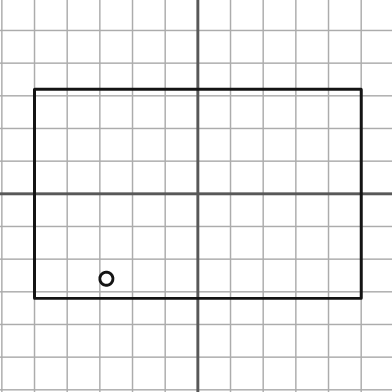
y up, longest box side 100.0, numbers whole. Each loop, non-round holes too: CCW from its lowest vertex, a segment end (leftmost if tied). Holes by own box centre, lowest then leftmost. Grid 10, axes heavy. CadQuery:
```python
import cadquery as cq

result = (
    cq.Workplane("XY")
    .moveTo(-50.0, -32.0)
    .lineTo(50.0, -32.0)
    .lineTo(50.0, 32.0)
    .lineTo(-50.0, 32.0)
    .close()
    .moveTo(-28.0, -26.0)
    .circle(2.0)
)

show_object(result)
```